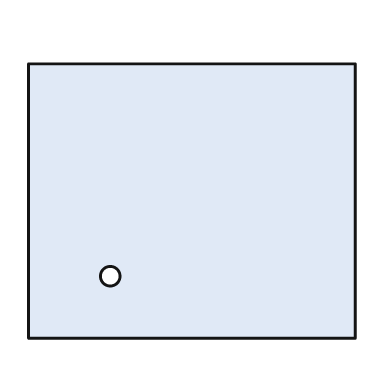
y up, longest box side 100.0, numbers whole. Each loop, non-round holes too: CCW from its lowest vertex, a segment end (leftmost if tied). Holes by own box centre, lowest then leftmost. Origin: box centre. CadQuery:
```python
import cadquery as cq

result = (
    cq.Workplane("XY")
    .moveTo(-50.0, -42.0)
    .lineTo(50.0, -42.0)
    .lineTo(50.0, 42.0)
    .lineTo(-50.0, 42.0)
    .close()
    .moveTo(-25.0, -23.0)
    .circle(3.0)
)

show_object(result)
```